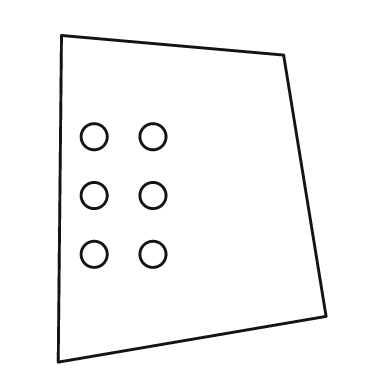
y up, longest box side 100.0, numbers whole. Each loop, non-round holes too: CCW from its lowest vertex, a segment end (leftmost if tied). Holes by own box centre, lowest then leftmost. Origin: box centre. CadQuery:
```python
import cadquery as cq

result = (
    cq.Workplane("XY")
    .moveTo(-41.0, -50.0)
    .lineTo(41.0, -36.0)
    .lineTo(28.0, 44.0)
    .lineTo(-40.0, 50.0)
    .close()
    .moveTo(-30.0, -17.0)
    .circle(4.0)
    .moveTo(-12.0, -17.0)
    .circle(4.0)
    .moveTo(-30.0, 1.0)
    .circle(4.0)
    .moveTo(-12.0, 1.0)
    .circle(4.0)
    .moveTo(-30.0, 19.0)
    .circle(4.0)
    .moveTo(-12.0, 19.0)
    .circle(4.0)
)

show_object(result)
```